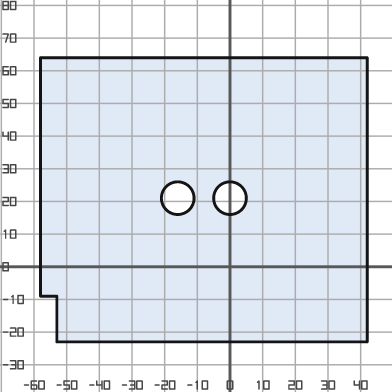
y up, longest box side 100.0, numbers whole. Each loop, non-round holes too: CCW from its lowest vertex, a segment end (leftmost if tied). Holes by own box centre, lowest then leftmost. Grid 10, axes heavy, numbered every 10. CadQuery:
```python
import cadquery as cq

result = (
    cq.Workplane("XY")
    .moveTo(-53.0, -23.0)
    .lineTo(42.0, -23.0)
    .lineTo(42.0, 64.0)
    .lineTo(-58.0, 64.0)
    .lineTo(-58.0, -9.0)
    .lineTo(-53.0, -9.0)
    .close()
    .moveTo(-16.0, 21.0)
    .circle(5.0)
    .moveTo(0.0, 21.0)
    .circle(5.0)
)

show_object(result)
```